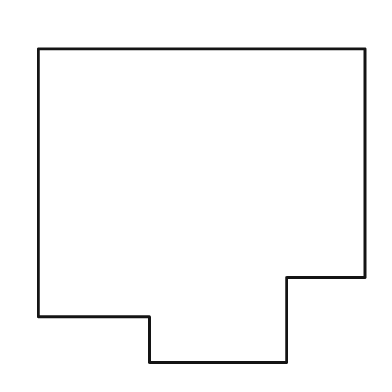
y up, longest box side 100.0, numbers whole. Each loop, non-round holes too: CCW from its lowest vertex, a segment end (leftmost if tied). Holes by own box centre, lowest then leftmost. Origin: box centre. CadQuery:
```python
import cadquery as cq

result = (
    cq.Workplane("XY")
    .moveTo(-16.0, -48.0)
    .lineTo(26.0, -48.0)
    .lineTo(26.0, -22.0)
    .lineTo(50.0, -22.0)
    .lineTo(50.0, 48.0)
    .lineTo(-50.0, 48.0)
    .lineTo(-50.0, -34.0)
    .lineTo(-16.0, -34.0)
    .close()
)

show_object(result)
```